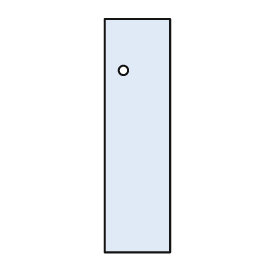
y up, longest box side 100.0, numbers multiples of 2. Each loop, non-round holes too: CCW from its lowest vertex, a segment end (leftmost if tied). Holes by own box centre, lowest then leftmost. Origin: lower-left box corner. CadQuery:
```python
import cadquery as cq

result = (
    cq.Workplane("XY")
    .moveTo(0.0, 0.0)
    .lineTo(28.0, 0.0)
    .lineTo(28.0, 100.0)
    .lineTo(0.0, 100.0)
    .close()
    .moveTo(8.0, 78.0)
    .circle(2.0)
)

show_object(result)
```